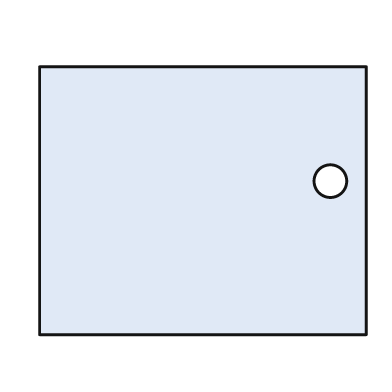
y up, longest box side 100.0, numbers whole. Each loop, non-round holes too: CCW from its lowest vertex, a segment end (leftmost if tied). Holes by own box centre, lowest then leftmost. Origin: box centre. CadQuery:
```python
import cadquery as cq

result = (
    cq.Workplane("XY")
    .moveTo(-50.0, -41.0)
    .lineTo(50.0, -41.0)
    .lineTo(50.0, 41.0)
    .lineTo(-50.0, 41.0)
    .close()
    .moveTo(39.0, 6.0)
    .circle(5.0)
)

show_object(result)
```